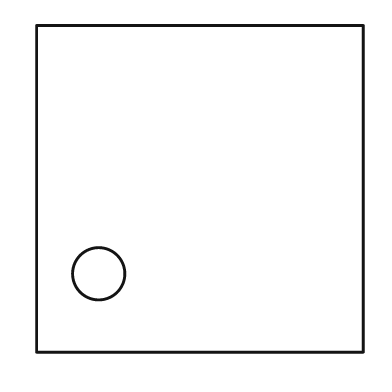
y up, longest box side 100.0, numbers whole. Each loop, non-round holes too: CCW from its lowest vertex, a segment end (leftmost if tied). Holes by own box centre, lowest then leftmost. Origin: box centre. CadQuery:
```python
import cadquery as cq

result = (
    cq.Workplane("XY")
    .moveTo(-50.0, -50.0)
    .lineTo(50.0, -50.0)
    .lineTo(50.0, 50.0)
    .lineTo(-50.0, 50.0)
    .close()
    .moveTo(-31.0, -26.0)
    .circle(8.0)
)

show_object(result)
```